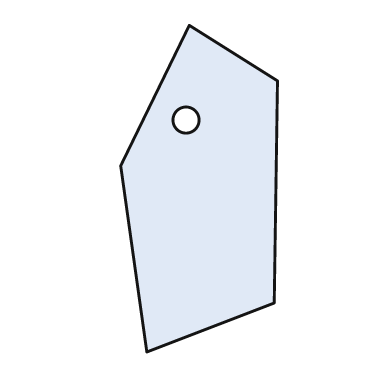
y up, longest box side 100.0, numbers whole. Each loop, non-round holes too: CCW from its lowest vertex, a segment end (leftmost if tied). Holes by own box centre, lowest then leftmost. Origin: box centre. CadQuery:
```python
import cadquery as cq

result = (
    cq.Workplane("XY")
    .moveTo(-16.0, -50.0)
    .lineTo(23.0, -35.0)
    .lineTo(24.0, 33.0)
    .lineTo(-3.0, 50.0)
    .lineTo(-24.0, 7.0)
    .close()
    .moveTo(-4.0, 21.0)
    .circle(4.0)
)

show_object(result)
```